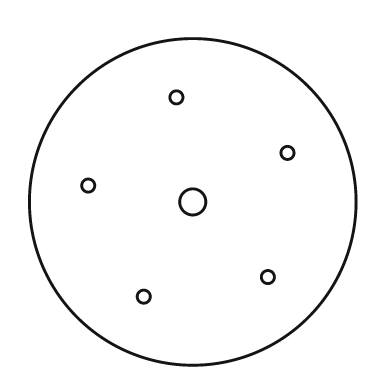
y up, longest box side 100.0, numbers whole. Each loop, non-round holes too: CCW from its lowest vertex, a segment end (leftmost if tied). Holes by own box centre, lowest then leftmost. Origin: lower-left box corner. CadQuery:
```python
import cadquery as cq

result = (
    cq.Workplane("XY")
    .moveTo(50.0, 50.0)
    .circle(50.0)
    .moveTo(35.0, 21.0)
    .circle(2.0)
    .moveTo(73.0, 27.0)
    .circle(2.0)
    .moveTo(50.0, 50.0)
    .circle(4.0)
    .moveTo(18.0, 55.0)
    .circle(2.0)
    .moveTo(79.0, 65.0)
    .circle(2.0)
    .moveTo(45.0, 82.0)
    .circle(2.0)
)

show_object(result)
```